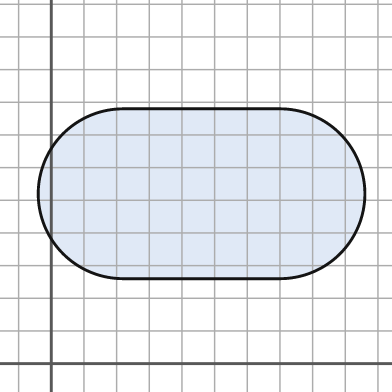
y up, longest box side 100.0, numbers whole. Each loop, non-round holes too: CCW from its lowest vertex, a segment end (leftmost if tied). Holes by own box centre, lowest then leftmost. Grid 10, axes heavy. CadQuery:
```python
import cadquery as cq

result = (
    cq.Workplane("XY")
    .moveTo(22.0, 26.0)
    .lineTo(70.0, 26.0)
    .threePointArc((96.0, 52.0), (70.0, 78.0))
    .lineTo(22.0, 78.0)
    .threePointArc((-4.0, 52.0), (22.0, 26.0))
    .close()
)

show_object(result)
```